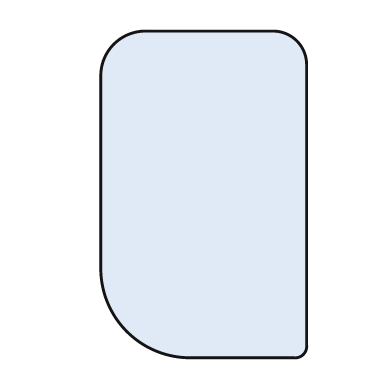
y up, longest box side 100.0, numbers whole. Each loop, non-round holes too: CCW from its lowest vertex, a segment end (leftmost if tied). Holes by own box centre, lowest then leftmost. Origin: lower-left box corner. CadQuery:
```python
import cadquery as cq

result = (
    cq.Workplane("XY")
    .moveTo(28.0, 0.0)
    .lineTo(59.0, 0.0)
    .threePointArc((62.0, 1.0), (63.0, 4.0))
    .lineTo(63.0, 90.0)
    .threePointArc((60.0, 97.0), (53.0, 100.0))
    .lineTo(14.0, 100.0)
    .threePointArc((4.0, 96.0), (0.0, 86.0))
    .lineTo(0.0, 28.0)
    .threePointArc((8.0, 8.0), (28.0, 0.0))
    .close()
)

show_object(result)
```